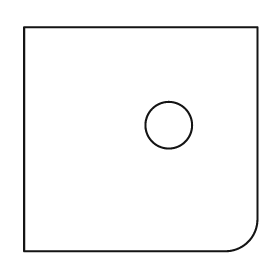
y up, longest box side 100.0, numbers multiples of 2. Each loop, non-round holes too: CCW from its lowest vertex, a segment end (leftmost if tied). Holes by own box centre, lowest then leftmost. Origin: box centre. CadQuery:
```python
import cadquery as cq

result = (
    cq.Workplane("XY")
    .moveTo(-50.0, -48.0)
    .lineTo(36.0, -48.0)
    .threePointArc((46.0, -44.0), (50.0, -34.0))
    .lineTo(50.0, 48.0)
    .lineTo(-50.0, 48.0)
    .close()
    .moveTo(12.0, 6.0)
    .circle(10.0)
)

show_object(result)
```